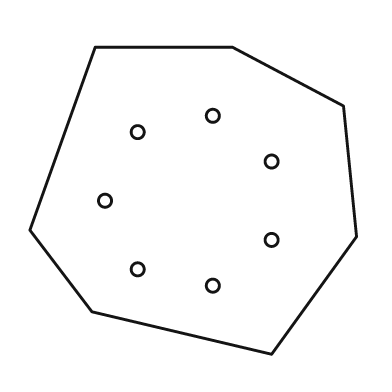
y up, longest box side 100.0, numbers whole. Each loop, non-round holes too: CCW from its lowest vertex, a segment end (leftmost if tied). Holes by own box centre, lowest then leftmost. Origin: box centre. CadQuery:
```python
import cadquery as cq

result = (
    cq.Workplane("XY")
    .moveTo(24.0, -47.0)
    .lineTo(50.0, -11.0)
    .lineTo(46.0, 29.0)
    .lineTo(12.0, 47.0)
    .lineTo(-30.0, 47.0)
    .lineTo(-50.0, -9.0)
    .lineTo(-31.0, -34.0)
    .close()
    .moveTo(6.0, -26.0)
    .circle(2.0)
    .moveTo(-17.0, -21.0)
    .circle(2.0)
    .moveTo(24.0, -12.0)
    .circle(2.0)
    .moveTo(-27.0, 0.0)
    .circle(2.0)
    .moveTo(24.0, 12.0)
    .circle(2.0)
    .moveTo(-17.0, 21.0)
    .circle(2.0)
    .moveTo(6.0, 26.0)
    .circle(2.0)
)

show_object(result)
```